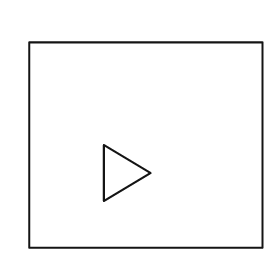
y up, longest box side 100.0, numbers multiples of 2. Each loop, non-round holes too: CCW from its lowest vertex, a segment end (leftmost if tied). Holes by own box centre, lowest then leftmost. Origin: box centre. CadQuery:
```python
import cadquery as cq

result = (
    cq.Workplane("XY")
    .moveTo(-50.0, -44.0)
    .lineTo(50.0, -44.0)
    .lineTo(50.0, 44.0)
    .lineTo(-50.0, 44.0)
    .close()
    .moveTo(-18.0, -24.0)
    .lineTo(2.0, -12.0)
    .lineTo(-18.0, 0.0)
    .close()
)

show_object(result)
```